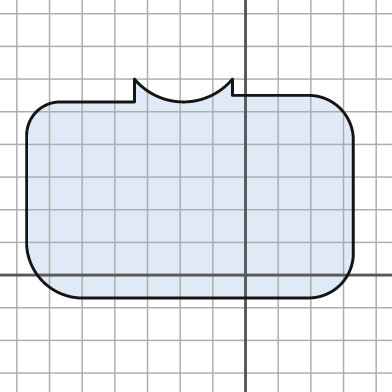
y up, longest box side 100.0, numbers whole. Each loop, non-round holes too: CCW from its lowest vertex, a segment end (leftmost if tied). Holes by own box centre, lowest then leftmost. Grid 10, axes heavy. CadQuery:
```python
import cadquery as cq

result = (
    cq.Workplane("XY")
    .moveTo(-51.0, -7.0)
    .lineTo(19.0, -7.0)
    .threePointArc((29.0, -3.0), (33.0, 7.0))
    .lineTo(33.0, 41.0)
    .threePointArc((29.0, 51.0), (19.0, 55.0))
    .lineTo(-4.0, 55.0)
    .lineTo(-4.0, 60.0)
    .threePointArc((-19.0, 53.0), (-34.0, 60.0))
    .lineTo(-34.0, 53.0)
    .lineTo(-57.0, 53.0)
    .threePointArc((-64.0, 50.0), (-67.0, 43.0))
    .lineTo(-67.0, 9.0)
    .threePointArc((-62.0, -2.0), (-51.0, -7.0))
    .close()
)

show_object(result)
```